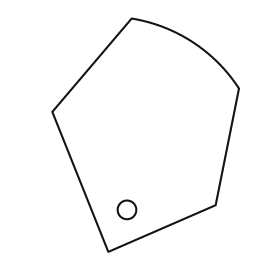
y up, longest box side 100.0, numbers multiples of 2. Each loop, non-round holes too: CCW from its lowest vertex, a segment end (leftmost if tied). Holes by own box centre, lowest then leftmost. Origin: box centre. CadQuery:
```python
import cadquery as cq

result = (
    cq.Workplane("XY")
    .moveTo(-16.0, -50.0)
    .lineTo(30.0, -30.0)
    .lineTo(40.0, 20.0)
    .threePointArc((20.0, 40.0), (-6.0, 50.0))
    .lineTo(-40.0, 10.0)
    .close()
    .moveTo(-8.0, -32.0)
    .circle(4.0)
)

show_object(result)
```